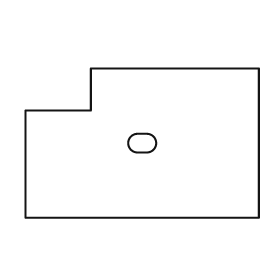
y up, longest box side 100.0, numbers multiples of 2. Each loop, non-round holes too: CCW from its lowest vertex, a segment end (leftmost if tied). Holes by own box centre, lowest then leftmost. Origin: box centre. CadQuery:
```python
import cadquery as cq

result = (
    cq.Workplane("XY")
    .moveTo(-50.0, -32.0)
    .lineTo(50.0, -32.0)
    .lineTo(50.0, 32.0)
    .lineTo(-22.0, 32.0)
    .lineTo(-22.0, 14.0)
    .lineTo(-50.0, 14.0)
    .close()
    .moveTo(-2.0, -4.0)
    .lineTo(2.0, -4.0)
    .threePointArc((6.0, 0.0), (2.0, 4.0))
    .lineTo(-2.0, 4.0)
    .threePointArc((-6.0, 0.0), (-2.0, -4.0))
    .close()
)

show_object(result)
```